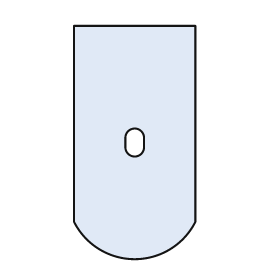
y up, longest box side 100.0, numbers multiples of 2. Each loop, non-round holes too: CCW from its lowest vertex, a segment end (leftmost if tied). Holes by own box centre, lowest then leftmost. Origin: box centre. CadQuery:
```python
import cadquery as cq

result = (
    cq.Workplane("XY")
    .moveTo(-26.0, -34.0)
    .threePointArc((0.0, -50.0), (26.0, -34.0))
    .lineTo(26.0, 50.0)
    .lineTo(-26.0, 50.0)
    .close()
    .moveTo(-4.0, -2.0)
    .threePointArc((0.0, -6.0), (4.0, -2.0))
    .lineTo(4.0, 2.0)
    .threePointArc((0.0, 6.0), (-4.0, 2.0))
    .close()
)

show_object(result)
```